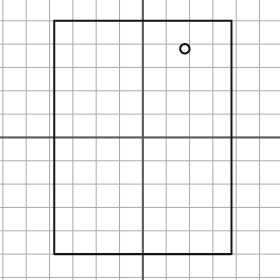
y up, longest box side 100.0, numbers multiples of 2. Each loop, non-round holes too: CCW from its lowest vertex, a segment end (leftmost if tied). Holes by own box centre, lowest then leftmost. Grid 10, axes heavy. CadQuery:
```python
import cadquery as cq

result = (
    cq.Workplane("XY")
    .moveTo(-38.0, -50.0)
    .lineTo(38.0, -50.0)
    .lineTo(38.0, 50.0)
    .lineTo(-38.0, 50.0)
    .close()
    .moveTo(18.0, 38.0)
    .circle(2.0)
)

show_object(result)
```